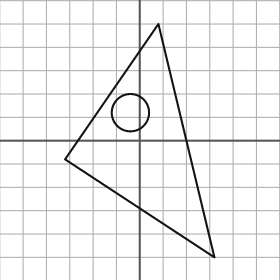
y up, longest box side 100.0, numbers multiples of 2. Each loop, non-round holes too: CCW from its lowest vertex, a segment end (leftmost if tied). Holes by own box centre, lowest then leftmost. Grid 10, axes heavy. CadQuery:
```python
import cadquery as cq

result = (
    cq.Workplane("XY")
    .moveTo(32.0, -50.0)
    .lineTo(8.0, 50.0)
    .lineTo(-32.0, -8.0)
    .close()
    .moveTo(-4.0, 12.0)
    .circle(8.0)
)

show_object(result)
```